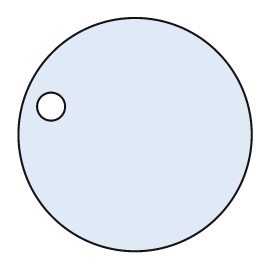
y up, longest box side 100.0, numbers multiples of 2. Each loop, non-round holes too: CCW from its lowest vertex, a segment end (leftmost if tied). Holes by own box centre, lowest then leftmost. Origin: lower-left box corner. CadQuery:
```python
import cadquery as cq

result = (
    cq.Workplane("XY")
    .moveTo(50.0, 50.0)
    .circle(50.0)
    .moveTo(14.0, 62.0)
    .circle(6.0)
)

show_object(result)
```